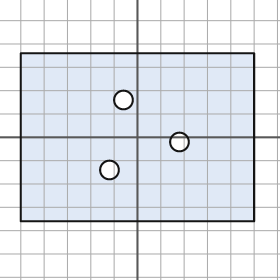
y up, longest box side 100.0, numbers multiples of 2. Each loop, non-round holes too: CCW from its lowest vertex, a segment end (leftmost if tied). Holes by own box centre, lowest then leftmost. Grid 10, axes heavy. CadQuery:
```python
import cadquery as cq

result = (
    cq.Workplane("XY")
    .moveTo(-50.0, -36.0)
    .lineTo(50.0, -36.0)
    .lineTo(50.0, 36.0)
    .lineTo(-50.0, 36.0)
    .close()
    .moveTo(-12.0, -14.0)
    .circle(4.0)
    .moveTo(18.0, -2.0)
    .circle(4.0)
    .moveTo(-6.0, 16.0)
    .circle(4.0)
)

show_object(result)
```